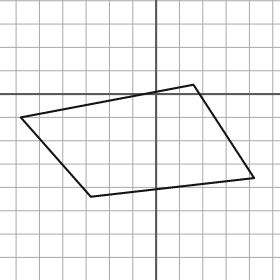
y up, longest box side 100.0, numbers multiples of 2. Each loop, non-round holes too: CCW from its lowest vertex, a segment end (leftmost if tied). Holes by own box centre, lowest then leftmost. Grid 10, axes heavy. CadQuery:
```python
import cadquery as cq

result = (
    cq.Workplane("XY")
    .moveTo(-28.0, -44.0)
    .lineTo(42.0, -36.0)
    .lineTo(16.0, 4.0)
    .lineTo(-58.0, -10.0)
    .close()
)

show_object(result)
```